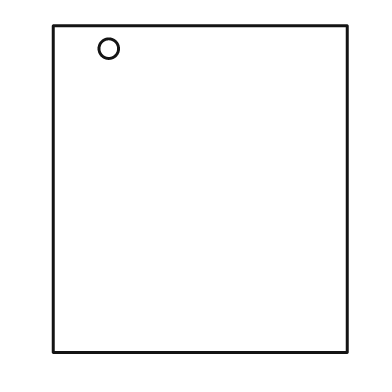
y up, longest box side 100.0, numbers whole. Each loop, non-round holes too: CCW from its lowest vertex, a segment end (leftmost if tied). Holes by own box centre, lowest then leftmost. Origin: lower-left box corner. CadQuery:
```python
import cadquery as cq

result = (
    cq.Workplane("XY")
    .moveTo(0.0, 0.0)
    .lineTo(90.0, 0.0)
    .lineTo(90.0, 100.0)
    .lineTo(0.0, 100.0)
    .close()
    .moveTo(17.0, 93.0)
    .circle(3.0)
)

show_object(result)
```